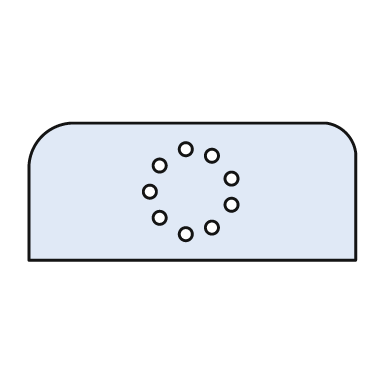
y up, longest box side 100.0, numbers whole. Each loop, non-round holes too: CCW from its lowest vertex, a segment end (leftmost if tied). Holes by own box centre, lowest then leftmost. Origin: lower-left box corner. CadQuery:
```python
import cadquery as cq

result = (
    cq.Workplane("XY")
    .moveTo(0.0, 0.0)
    .lineTo(100.0, 0.0)
    .lineTo(100.0, 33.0)
    .threePointArc((97.0, 39.0), (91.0, 42.0))
    .lineTo(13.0, 42.0)
    .threePointArc((4.0, 38.0), (0.0, 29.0))
    .close()
    .moveTo(48.0, 8.0)
    .circle(2.0)
    .moveTo(56.0, 10.0)
    .circle(2.0)
    .moveTo(40.0, 13.0)
    .circle(2.0)
    .moveTo(62.0, 17.0)
    .circle(2.0)
    .moveTo(37.0, 21.0)
    .circle(2.0)
    .moveTo(62.0, 25.0)
    .circle(2.0)
    .moveTo(40.0, 29.0)
    .circle(2.0)
    .moveTo(56.0, 32.0)
    .circle(2.0)
    .moveTo(48.0, 34.0)
    .circle(2.0)
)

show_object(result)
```